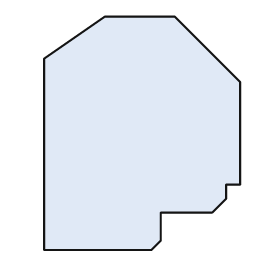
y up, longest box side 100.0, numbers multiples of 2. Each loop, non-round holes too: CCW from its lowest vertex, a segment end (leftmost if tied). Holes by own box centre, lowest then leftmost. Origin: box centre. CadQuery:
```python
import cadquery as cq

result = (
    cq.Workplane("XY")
    .moveTo(-42.0, -50.0)
    .lineTo(4.0, -50.0)
    .lineTo(8.0, -46.0)
    .lineTo(8.0, -34.0)
    .lineTo(30.0, -34.0)
    .lineTo(36.0, -28.0)
    .lineTo(36.0, -22.0)
    .lineTo(42.0, -22.0)
    .lineTo(42.0, 22.0)
    .lineTo(14.0, 50.0)
    .lineTo(-16.0, 50.0)
    .lineTo(-42.0, 32.0)
    .close()
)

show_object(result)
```